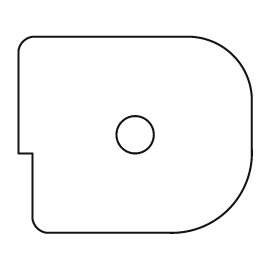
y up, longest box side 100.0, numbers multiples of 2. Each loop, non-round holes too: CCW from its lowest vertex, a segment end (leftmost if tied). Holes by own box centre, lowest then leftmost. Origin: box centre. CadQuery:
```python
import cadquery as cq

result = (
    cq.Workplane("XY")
    .moveTo(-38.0, -42.0)
    .lineTo(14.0, -42.0)
    .threePointArc((40.0, -32.0), (50.0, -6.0))
    .lineTo(50.0, 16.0)
    .threePointArc((42.0, 34.0), (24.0, 42.0))
    .lineTo(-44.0, 42.0)
    .threePointArc((-48.0, 40.0), (-50.0, 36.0))
    .lineTo(-50.0, -8.0)
    .lineTo(-44.0, -8.0)
    .lineTo(-44.0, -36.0)
    .threePointArc((-42.0, -40.0), (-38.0, -42.0))
    .close()
    .moveTo(0.0, 0.0)
    .circle(8.0)
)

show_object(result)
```